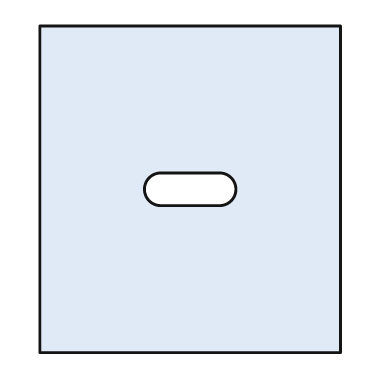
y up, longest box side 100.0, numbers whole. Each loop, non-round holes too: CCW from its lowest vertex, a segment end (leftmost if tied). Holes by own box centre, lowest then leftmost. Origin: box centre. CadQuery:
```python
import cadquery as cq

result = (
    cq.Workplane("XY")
    .moveTo(-46.0, -50.0)
    .lineTo(46.0, -50.0)
    .lineTo(46.0, 50.0)
    .lineTo(-46.0, 50.0)
    .close()
    .moveTo(-9.0, -5.0)
    .lineTo(9.0, -5.0)
    .threePointArc((14.0, 0.0), (9.0, 5.0))
    .lineTo(-9.0, 5.0)
    .threePointArc((-14.0, 0.0), (-9.0, -5.0))
    .close()
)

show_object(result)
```